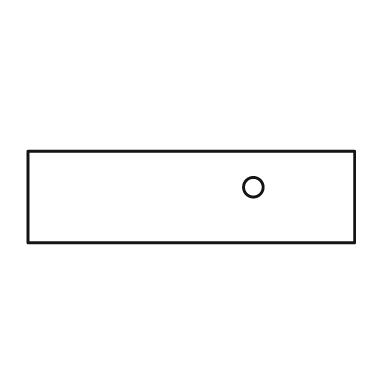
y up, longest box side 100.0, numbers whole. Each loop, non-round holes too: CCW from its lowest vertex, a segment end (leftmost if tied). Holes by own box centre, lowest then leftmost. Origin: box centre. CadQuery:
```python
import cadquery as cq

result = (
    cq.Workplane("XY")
    .moveTo(-50.0, -14.0)
    .lineTo(50.0, -14.0)
    .lineTo(50.0, 14.0)
    .lineTo(-50.0, 14.0)
    .close()
    .moveTo(19.0, 3.0)
    .circle(3.0)
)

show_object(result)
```